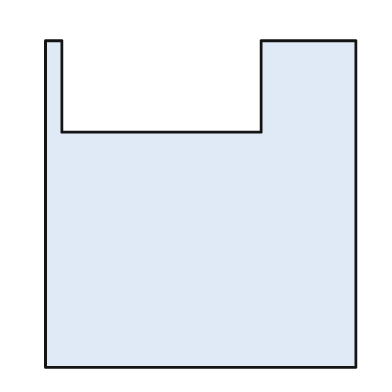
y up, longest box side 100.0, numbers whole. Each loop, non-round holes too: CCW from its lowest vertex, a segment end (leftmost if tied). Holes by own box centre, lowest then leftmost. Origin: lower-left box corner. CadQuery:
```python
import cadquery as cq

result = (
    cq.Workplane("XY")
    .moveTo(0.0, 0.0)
    .lineTo(95.0, 0.0)
    .lineTo(95.0, 100.0)
    .lineTo(66.0, 100.0)
    .lineTo(66.0, 72.0)
    .lineTo(5.0, 72.0)
    .lineTo(5.0, 100.0)
    .lineTo(0.0, 100.0)
    .close()
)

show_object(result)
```